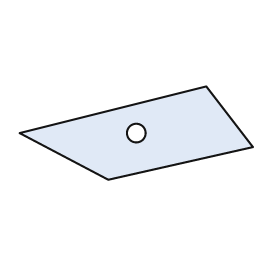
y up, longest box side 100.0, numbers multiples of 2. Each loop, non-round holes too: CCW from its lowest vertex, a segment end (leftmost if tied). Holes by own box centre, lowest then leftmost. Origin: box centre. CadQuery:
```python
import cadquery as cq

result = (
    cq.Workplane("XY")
    .moveTo(-12.0, -20.0)
    .lineTo(50.0, -6.0)
    .lineTo(30.0, 20.0)
    .lineTo(-50.0, 0.0)
    .close()
    .moveTo(0.0, 0.0)
    .circle(4.0)
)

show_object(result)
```